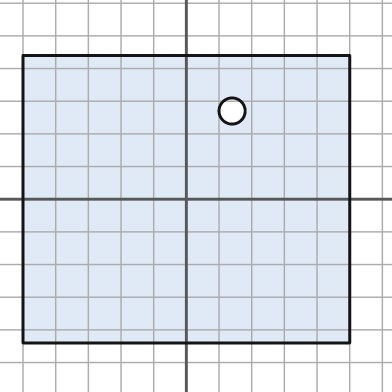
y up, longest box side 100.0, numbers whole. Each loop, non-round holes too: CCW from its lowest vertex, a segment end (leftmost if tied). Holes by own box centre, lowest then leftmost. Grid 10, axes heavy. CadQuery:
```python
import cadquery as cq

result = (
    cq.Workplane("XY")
    .moveTo(-50.0, -44.0)
    .lineTo(50.0, -44.0)
    .lineTo(50.0, 44.0)
    .lineTo(-50.0, 44.0)
    .close()
    .moveTo(14.0, 27.0)
    .circle(4.0)
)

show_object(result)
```